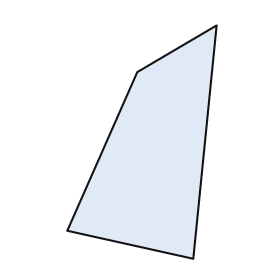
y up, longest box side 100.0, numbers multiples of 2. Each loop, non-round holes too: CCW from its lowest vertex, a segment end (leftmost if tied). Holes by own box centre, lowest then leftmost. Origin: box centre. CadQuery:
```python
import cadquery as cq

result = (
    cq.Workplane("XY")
    .moveTo(22.0, -50.0)
    .lineTo(32.0, 50.0)
    .lineTo(-2.0, 30.0)
    .lineTo(-32.0, -38.0)
    .close()
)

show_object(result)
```